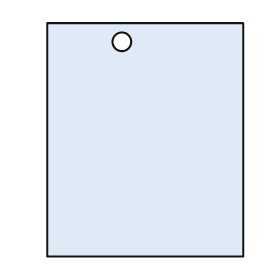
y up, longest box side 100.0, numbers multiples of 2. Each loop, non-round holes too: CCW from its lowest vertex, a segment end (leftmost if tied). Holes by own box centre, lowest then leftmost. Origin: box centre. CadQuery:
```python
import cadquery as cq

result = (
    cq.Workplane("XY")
    .moveTo(-42.0, -50.0)
    .lineTo(42.0, -50.0)
    .lineTo(42.0, 50.0)
    .lineTo(-42.0, 50.0)
    .close()
    .moveTo(-10.0, 42.0)
    .circle(4.0)
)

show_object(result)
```